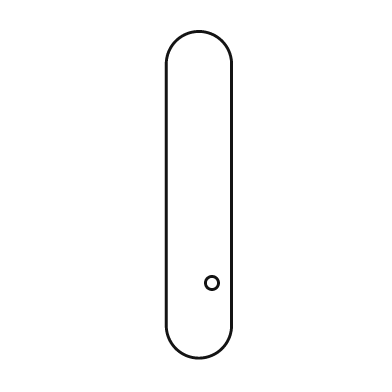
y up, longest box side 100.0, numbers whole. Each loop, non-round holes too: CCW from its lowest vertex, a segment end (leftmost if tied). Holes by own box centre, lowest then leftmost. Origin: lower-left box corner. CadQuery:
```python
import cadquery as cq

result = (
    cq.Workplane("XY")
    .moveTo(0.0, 10.0)
    .threePointArc((10.0, 0.0), (20.0, 10.0))
    .lineTo(20.0, 90.0)
    .threePointArc((10.0, 100.0), (0.0, 90.0))
    .close()
    .moveTo(14.0, 23.0)
    .circle(2.0)
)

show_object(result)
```